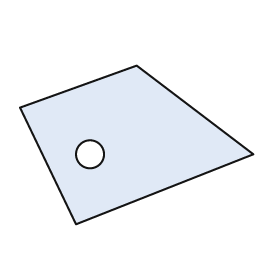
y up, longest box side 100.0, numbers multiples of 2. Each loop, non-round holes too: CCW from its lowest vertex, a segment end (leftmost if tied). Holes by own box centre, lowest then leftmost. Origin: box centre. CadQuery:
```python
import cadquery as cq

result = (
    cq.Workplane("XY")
    .moveTo(-26.0, -34.0)
    .lineTo(50.0, -4.0)
    .lineTo(0.0, 34.0)
    .lineTo(-50.0, 16.0)
    .close()
    .moveTo(-20.0, -4.0)
    .circle(6.0)
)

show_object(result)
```